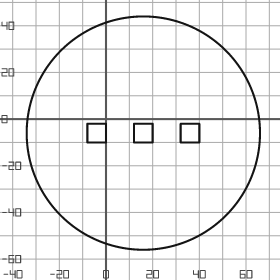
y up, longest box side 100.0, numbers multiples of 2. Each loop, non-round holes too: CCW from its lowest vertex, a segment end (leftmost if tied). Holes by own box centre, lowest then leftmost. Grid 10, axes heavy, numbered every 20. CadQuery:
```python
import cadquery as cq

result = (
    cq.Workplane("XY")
    .moveTo(16.0, -6.0)
    .circle(50.0)
    .moveTo(-8.0, -10.0)
    .lineTo(0.0, -10.0)
    .lineTo(0.0, -2.0)
    .lineTo(-8.0, -2.0)
    .close()
    .moveTo(12.0, -10.0)
    .lineTo(20.0, -10.0)
    .lineTo(20.0, -2.0)
    .lineTo(12.0, -2.0)
    .close()
    .moveTo(32.0, -10.0)
    .lineTo(40.0, -10.0)
    .lineTo(40.0, -2.0)
    .lineTo(32.0, -2.0)
    .close()
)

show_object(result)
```